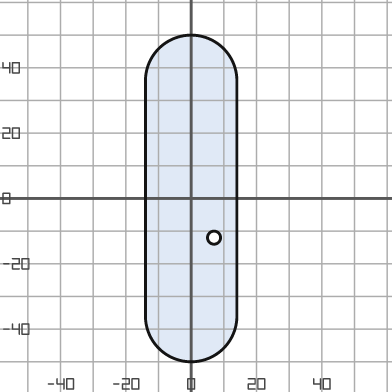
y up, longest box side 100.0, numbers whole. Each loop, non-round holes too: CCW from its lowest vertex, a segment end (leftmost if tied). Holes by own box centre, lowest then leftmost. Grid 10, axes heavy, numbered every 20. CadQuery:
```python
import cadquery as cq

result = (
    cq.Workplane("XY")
    .moveTo(-14.0, -36.0)
    .threePointArc((0.0, -50.0), (14.0, -36.0))
    .lineTo(14.0, 36.0)
    .threePointArc((0.0, 50.0), (-14.0, 36.0))
    .close()
    .moveTo(7.0, -12.0)
    .circle(2.0)
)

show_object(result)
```